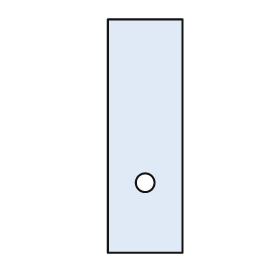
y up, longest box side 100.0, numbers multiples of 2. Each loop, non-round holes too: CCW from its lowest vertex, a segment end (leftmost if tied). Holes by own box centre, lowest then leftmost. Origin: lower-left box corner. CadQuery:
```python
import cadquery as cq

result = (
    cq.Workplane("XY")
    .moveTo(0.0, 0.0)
    .lineTo(32.0, 0.0)
    .lineTo(32.0, 100.0)
    .lineTo(0.0, 100.0)
    .close()
    .moveTo(16.0, 30.0)
    .circle(4.0)
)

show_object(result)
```